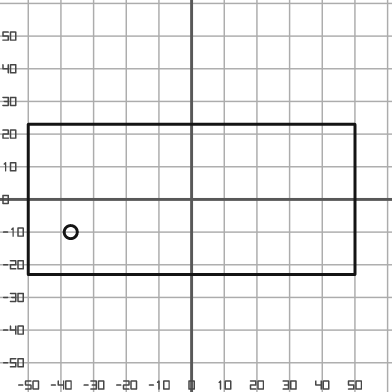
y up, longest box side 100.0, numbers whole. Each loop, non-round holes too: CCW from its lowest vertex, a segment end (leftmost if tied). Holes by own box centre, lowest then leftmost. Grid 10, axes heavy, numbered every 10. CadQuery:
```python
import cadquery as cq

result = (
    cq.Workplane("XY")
    .moveTo(-50.0, -23.0)
    .lineTo(50.0, -23.0)
    .lineTo(50.0, 23.0)
    .lineTo(-50.0, 23.0)
    .close()
    .moveTo(-37.0, -10.0)
    .circle(2.0)
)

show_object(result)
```